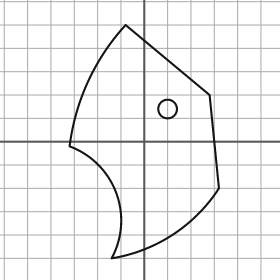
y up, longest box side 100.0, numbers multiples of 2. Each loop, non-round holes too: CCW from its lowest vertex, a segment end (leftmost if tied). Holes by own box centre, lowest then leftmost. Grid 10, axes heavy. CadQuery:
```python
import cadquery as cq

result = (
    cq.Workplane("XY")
    .moveTo(-14.0, -50.0)
    .threePointArc((12.0, -40.0), (32.0, -20.0))
    .lineTo(28.0, 20.0)
    .lineTo(-8.0, 50.0)
    .threePointArc((-24.0, 26.0), (-32.0, -2.0))
    .threePointArc((-12.0, -22.0), (-14.0, -50.0))
    .close()
    .moveTo(10.0, 14.0)
    .circle(4.0)
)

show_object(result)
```